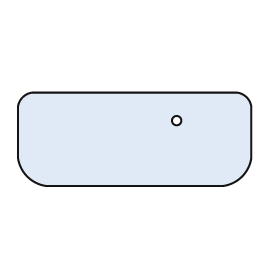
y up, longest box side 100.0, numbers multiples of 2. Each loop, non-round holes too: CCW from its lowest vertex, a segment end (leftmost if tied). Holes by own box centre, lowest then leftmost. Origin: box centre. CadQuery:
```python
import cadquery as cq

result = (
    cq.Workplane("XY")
    .moveTo(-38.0, -20.0)
    .lineTo(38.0, -20.0)
    .threePointArc((46.0, -16.0), (50.0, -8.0))
    .lineTo(50.0, 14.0)
    .threePointArc((48.0, 18.0), (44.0, 20.0))
    .lineTo(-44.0, 20.0)
    .threePointArc((-48.0, 18.0), (-50.0, 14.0))
    .lineTo(-50.0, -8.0)
    .threePointArc((-46.0, -16.0), (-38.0, -20.0))
    .close()
    .moveTo(18.0, 8.0)
    .circle(2.0)
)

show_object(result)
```